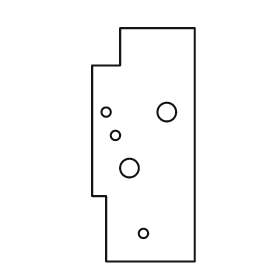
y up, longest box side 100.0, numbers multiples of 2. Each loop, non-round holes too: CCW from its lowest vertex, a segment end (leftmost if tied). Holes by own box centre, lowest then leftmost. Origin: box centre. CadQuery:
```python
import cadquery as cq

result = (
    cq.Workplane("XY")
    .moveTo(-16.0, -50.0)
    .lineTo(22.0, -50.0)
    .lineTo(22.0, 50.0)
    .lineTo(-10.0, 50.0)
    .lineTo(-10.0, 34.0)
    .lineTo(-22.0, 34.0)
    .lineTo(-22.0, -22.0)
    .lineTo(-16.0, -22.0)
    .close()
    .moveTo(0.0, -38.0)
    .circle(2.0)
    .moveTo(-6.0, -10.0)
    .circle(4.0)
    .moveTo(-12.0, 4.0)
    .circle(2.0)
    .moveTo(-16.0, 14.0)
    .circle(2.0)
    .moveTo(10.0, 14.0)
    .circle(4.0)
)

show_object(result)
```